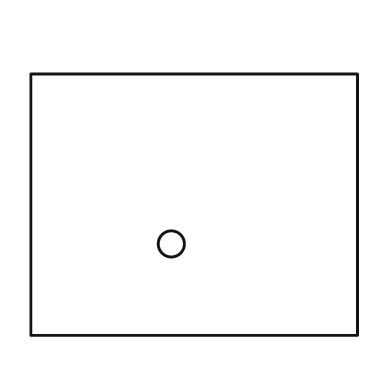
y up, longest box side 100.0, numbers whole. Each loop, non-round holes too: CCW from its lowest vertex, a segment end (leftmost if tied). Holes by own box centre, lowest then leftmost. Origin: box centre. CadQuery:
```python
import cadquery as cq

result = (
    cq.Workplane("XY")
    .moveTo(-50.0, -40.0)
    .lineTo(50.0, -40.0)
    .lineTo(50.0, 40.0)
    .lineTo(-50.0, 40.0)
    .close()
    .moveTo(-7.0, -12.0)
    .circle(4.0)
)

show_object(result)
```